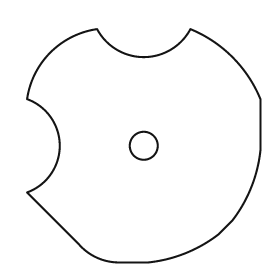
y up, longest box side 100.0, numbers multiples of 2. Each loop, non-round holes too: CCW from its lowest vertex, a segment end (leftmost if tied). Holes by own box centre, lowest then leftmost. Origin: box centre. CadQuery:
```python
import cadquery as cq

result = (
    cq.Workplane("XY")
    .moveTo(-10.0, -50.0)
    .lineTo(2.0, -50.0)
    .threePointArc((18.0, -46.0), (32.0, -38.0))
    .lineTo(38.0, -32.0)
    .threePointArc((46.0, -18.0), (50.0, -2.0))
    .lineTo(50.0, 20.0)
    .threePointArc((38.0, 38.0), (20.0, 50.0))
    .threePointArc((0.0, 38.0), (-20.0, 50.0))
    .threePointArc((-40.0, 40.0), (-50.0, 20.0))
    .threePointArc((-36.0, 0.0), (-50.0, -20.0))
    .lineTo(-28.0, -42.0)
    .threePointArc((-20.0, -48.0), (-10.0, -50.0))
    .close()
    .moveTo(0.0, 0.0)
    .circle(6.0)
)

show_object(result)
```